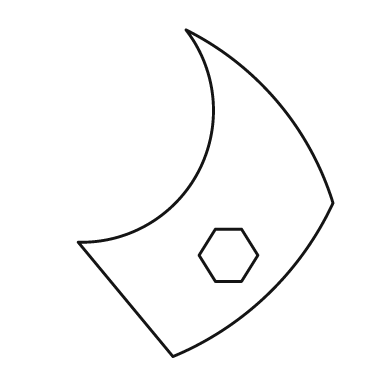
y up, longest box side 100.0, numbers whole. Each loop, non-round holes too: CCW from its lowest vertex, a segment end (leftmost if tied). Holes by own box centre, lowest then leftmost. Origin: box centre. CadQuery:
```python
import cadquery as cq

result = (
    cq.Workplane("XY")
    .moveTo(-10.0, -50.0)
    .threePointArc((19.0, -31.0), (39.0, -3.0))
    .threePointArc((22.0, 28.0), (-6.0, 50.0))
    .threePointArc((-2.0, 7.0), (-39.0, -15.0))
    .close()
    .moveTo(3.0, -27.0)
    .lineTo(11.0, -27.0)
    .lineTo(16.0, -19.0)
    .lineTo(11.0, -11.0)
    .lineTo(3.0, -11.0)
    .lineTo(-2.0, -19.0)
    .close()
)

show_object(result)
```